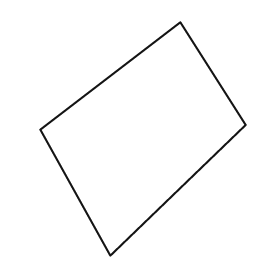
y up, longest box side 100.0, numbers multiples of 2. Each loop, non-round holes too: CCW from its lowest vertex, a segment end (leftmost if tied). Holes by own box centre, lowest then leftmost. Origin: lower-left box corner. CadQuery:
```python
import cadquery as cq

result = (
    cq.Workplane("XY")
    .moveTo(30.0, 0.0)
    .lineTo(88.0, 56.0)
    .lineTo(60.0, 100.0)
    .lineTo(0.0, 54.0)
    .close()
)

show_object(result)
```